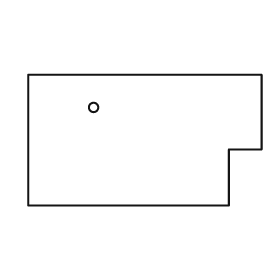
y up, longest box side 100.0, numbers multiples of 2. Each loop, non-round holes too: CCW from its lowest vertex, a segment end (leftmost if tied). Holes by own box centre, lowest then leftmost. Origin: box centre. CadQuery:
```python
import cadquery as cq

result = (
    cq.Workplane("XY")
    .moveTo(-50.0, -28.0)
    .lineTo(36.0, -28.0)
    .lineTo(36.0, -4.0)
    .lineTo(50.0, -4.0)
    .lineTo(50.0, 28.0)
    .lineTo(-50.0, 28.0)
    .close()
    .moveTo(-22.0, 14.0)
    .circle(2.0)
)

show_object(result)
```